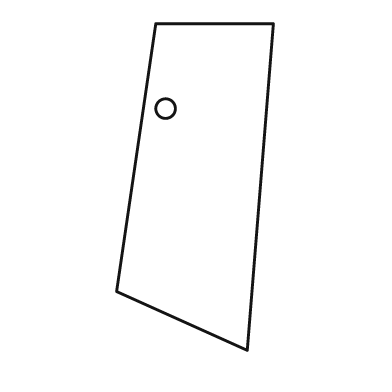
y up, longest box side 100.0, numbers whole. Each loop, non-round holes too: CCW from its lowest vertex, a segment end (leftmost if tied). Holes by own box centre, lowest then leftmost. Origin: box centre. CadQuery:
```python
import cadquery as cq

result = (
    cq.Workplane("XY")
    .moveTo(16.0, -50.0)
    .lineTo(24.0, 50.0)
    .lineTo(-12.0, 50.0)
    .lineTo(-24.0, -32.0)
    .close()
    .moveTo(-9.0, 24.0)
    .circle(3.0)
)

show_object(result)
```